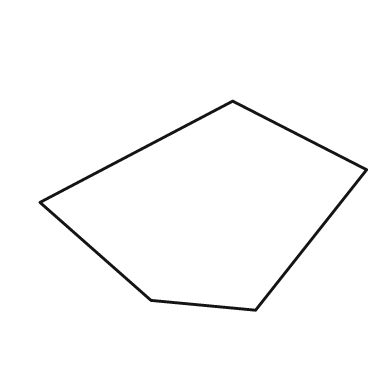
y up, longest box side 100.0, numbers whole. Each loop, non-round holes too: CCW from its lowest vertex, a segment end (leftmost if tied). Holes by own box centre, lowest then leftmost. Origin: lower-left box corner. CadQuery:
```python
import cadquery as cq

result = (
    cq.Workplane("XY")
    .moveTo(66.0, 0.0)
    .lineTo(100.0, 43.0)
    .lineTo(59.0, 64.0)
    .lineTo(0.0, 33.0)
    .lineTo(34.0, 3.0)
    .close()
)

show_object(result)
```